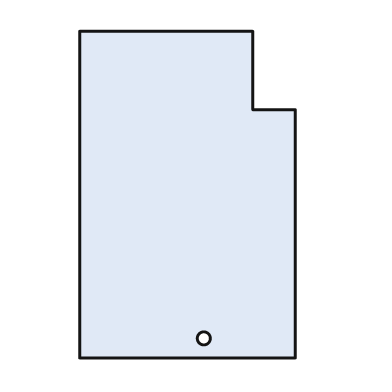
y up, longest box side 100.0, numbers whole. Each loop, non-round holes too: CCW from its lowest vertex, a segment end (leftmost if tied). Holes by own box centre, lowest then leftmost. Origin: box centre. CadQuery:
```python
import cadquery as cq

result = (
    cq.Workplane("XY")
    .moveTo(-33.0, -50.0)
    .lineTo(33.0, -50.0)
    .lineTo(33.0, 26.0)
    .lineTo(20.0, 26.0)
    .lineTo(20.0, 50.0)
    .lineTo(-33.0, 50.0)
    .close()
    .moveTo(5.0, -44.0)
    .circle(2.0)
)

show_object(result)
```